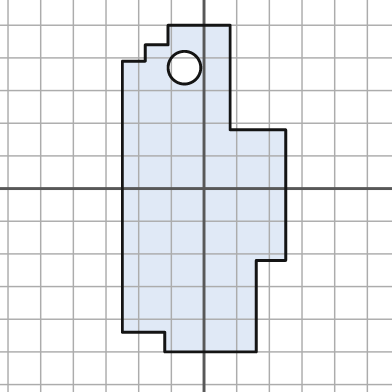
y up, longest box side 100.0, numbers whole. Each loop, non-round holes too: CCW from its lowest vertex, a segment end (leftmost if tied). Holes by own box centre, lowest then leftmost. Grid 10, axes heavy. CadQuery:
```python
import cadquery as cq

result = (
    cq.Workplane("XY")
    .moveTo(-12.0, -50.0)
    .lineTo(16.0, -50.0)
    .lineTo(16.0, -22.0)
    .lineTo(25.0, -22.0)
    .lineTo(25.0, 18.0)
    .lineTo(8.0, 18.0)
    .lineTo(8.0, 50.0)
    .lineTo(-11.0, 50.0)
    .lineTo(-11.0, 44.0)
    .lineTo(-18.0, 44.0)
    .lineTo(-18.0, 39.0)
    .lineTo(-25.0, 39.0)
    .lineTo(-25.0, -44.0)
    .lineTo(-12.0, -44.0)
    .close()
    .moveTo(-6.0, 37.0)
    .circle(5.0)
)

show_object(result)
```